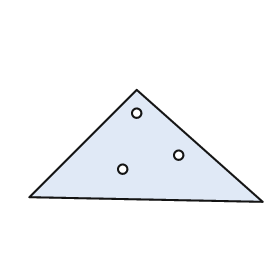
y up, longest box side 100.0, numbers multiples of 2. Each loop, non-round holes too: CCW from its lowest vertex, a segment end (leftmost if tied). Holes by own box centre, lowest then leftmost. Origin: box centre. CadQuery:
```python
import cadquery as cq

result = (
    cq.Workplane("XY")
    .moveTo(50.0, -24.0)
    .lineTo(-4.0, 24.0)
    .lineTo(-50.0, -22.0)
    .close()
    .moveTo(-10.0, -10.0)
    .circle(2.0)
    .moveTo(14.0, -4.0)
    .circle(2.0)
    .moveTo(-4.0, 14.0)
    .circle(2.0)
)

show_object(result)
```